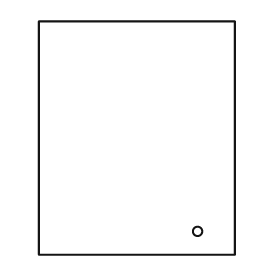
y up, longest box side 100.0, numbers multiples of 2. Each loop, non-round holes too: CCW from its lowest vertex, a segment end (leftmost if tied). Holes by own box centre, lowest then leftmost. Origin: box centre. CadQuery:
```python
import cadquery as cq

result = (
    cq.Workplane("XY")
    .moveTo(-42.0, -50.0)
    .lineTo(42.0, -50.0)
    .lineTo(42.0, 50.0)
    .lineTo(-42.0, 50.0)
    .close()
    .moveTo(26.0, -40.0)
    .circle(2.0)
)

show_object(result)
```